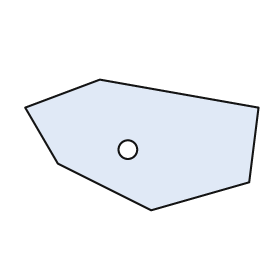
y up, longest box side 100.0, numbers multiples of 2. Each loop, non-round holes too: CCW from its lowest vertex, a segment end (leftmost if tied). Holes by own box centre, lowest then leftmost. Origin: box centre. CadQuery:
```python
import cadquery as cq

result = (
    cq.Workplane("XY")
    .moveTo(4.0, -28.0)
    .lineTo(46.0, -16.0)
    .lineTo(50.0, 16.0)
    .lineTo(-18.0, 28.0)
    .lineTo(-50.0, 16.0)
    .lineTo(-36.0, -8.0)
    .close()
    .moveTo(-6.0, -2.0)
    .circle(4.0)
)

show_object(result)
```